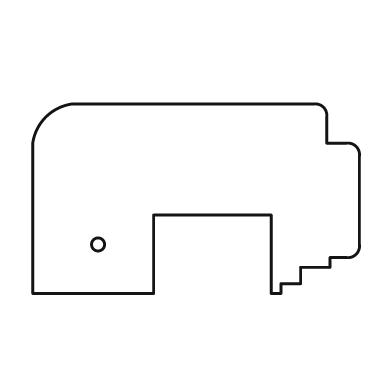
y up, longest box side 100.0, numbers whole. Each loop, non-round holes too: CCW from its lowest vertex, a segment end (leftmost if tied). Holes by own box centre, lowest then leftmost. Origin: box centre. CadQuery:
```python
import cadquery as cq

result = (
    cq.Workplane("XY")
    .moveTo(-50.0, -29.0)
    .lineTo(-13.0, -29.0)
    .lineTo(-13.0, -5.0)
    .lineTo(23.0, -5.0)
    .lineTo(23.0, -29.0)
    .lineTo(26.0, -29.0)
    .lineTo(26.0, -26.0)
    .lineTo(32.0, -26.0)
    .lineTo(32.0, -21.0)
    .lineTo(41.0, -21.0)
    .lineTo(41.0, -18.0)
    .lineTo(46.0, -18.0)
    .threePointArc((49.0, -17.0), (50.0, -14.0))
    .lineTo(50.0, 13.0)
    .threePointArc((49.0, 16.0), (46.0, 17.0))
    .lineTo(40.0, 17.0)
    .lineTo(40.0, 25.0)
    .threePointArc((39.0, 28.0), (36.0, 29.0))
    .lineTo(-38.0, 29.0)
    .threePointArc((-46.0, 25.0), (-50.0, 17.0))
    .close()
    .moveTo(-30.0, -14.0)
    .circle(2.0)
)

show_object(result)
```